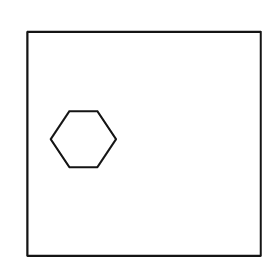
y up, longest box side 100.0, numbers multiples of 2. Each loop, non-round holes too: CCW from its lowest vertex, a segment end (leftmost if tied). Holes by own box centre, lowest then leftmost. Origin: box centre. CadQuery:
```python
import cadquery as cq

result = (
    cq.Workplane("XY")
    .moveTo(-50.0, -48.0)
    .lineTo(50.0, -48.0)
    .lineTo(50.0, 48.0)
    .lineTo(-50.0, 48.0)
    .close()
    .moveTo(-32.0, -10.0)
    .lineTo(-20.0, -10.0)
    .lineTo(-12.0, 2.0)
    .lineTo(-20.0, 14.0)
    .lineTo(-32.0, 14.0)
    .lineTo(-40.0, 2.0)
    .close()
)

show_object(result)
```